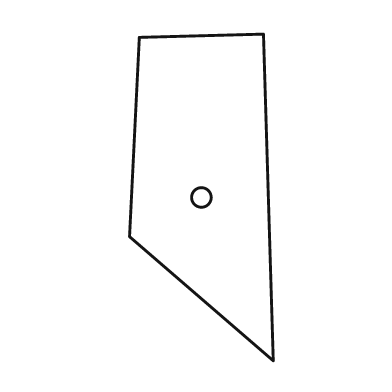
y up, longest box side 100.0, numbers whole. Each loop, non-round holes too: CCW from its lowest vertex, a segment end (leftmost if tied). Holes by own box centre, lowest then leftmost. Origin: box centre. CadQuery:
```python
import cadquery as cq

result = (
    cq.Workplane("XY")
    .moveTo(22.0, -50.0)
    .lineTo(19.0, 50.0)
    .lineTo(-19.0, 49.0)
    .lineTo(-22.0, -12.0)
    .close()
    .moveTo(0.0, 0.0)
    .circle(3.0)
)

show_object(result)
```